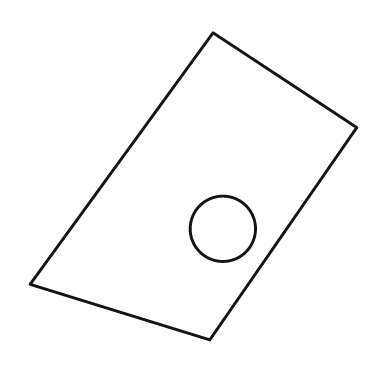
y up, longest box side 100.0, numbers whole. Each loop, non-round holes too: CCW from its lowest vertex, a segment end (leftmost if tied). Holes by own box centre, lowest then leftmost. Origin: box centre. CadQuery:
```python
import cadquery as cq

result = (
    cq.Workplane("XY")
    .moveTo(5.0, -47.0)
    .lineTo(50.0, 18.0)
    .lineTo(6.0, 47.0)
    .lineTo(-50.0, -30.0)
    .close()
    .moveTo(9.0, -13.0)
    .circle(10.0)
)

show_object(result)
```